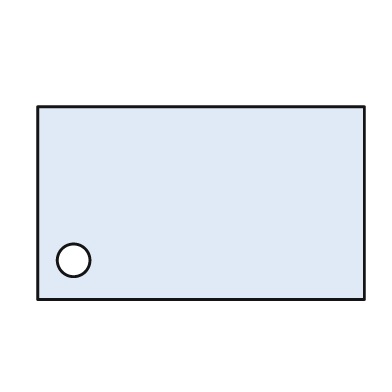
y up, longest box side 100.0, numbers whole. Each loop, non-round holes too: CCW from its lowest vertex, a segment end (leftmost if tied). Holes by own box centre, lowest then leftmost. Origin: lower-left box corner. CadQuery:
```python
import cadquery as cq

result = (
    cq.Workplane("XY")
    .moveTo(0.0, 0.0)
    .lineTo(100.0, 0.0)
    .lineTo(100.0, 59.0)
    .lineTo(0.0, 59.0)
    .close()
    .moveTo(11.0, 12.0)
    .circle(5.0)
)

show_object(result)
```